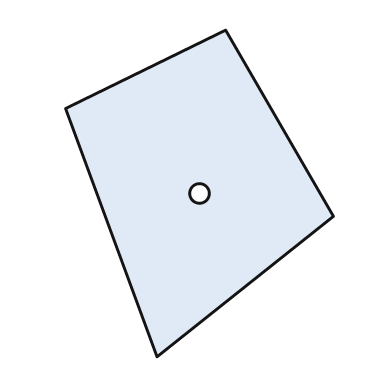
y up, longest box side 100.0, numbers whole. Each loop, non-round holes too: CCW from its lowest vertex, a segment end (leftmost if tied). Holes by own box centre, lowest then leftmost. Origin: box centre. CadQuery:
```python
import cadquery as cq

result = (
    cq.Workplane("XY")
    .moveTo(-13.0, -50.0)
    .lineTo(41.0, -7.0)
    .lineTo(8.0, 50.0)
    .lineTo(-41.0, 26.0)
    .close()
    .moveTo(0.0, 0.0)
    .circle(3.0)
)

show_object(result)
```